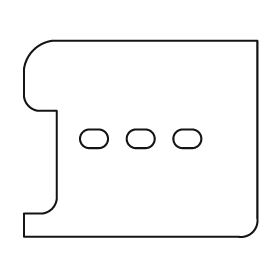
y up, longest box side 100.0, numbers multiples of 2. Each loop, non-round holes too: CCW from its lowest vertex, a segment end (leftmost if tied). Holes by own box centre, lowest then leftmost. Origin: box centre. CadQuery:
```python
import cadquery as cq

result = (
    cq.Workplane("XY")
    .moveTo(-50.0, -42.0)
    .lineTo(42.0, -42.0)
    .threePointArc((48.0, -40.0), (50.0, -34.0))
    .lineTo(50.0, 42.0)
    .lineTo(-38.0, 42.0)
    .threePointArc((-46.0, 38.0), (-50.0, 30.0))
    .lineTo(-50.0, 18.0)
    .threePointArc((-48.0, 14.0), (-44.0, 12.0))
    .lineTo(-36.0, 12.0)
    .lineTo(-36.0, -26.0)
    .threePointArc((-38.0, -30.0), (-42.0, -32.0))
    .lineTo(-50.0, -32.0)
    .close()
    .moveTo(-22.0, -4.0)
    .lineTo(-18.0, -4.0)
    .threePointArc((-14.0, 0.0), (-18.0, 4.0))
    .lineTo(-22.0, 4.0)
    .threePointArc((-26.0, 0.0), (-22.0, -4.0))
    .close()
    .moveTo(-2.0, -4.0)
    .lineTo(2.0, -4.0)
    .threePointArc((6.0, 0.0), (2.0, 4.0))
    .lineTo(-2.0, 4.0)
    .threePointArc((-6.0, 0.0), (-2.0, -4.0))
    .close()
    .moveTo(18.0, -4.0)
    .lineTo(22.0, -4.0)
    .threePointArc((26.0, 0.0), (22.0, 4.0))
    .lineTo(18.0, 4.0)
    .threePointArc((14.0, 0.0), (18.0, -4.0))
    .close()
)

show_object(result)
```